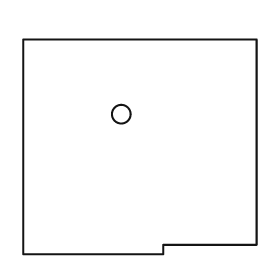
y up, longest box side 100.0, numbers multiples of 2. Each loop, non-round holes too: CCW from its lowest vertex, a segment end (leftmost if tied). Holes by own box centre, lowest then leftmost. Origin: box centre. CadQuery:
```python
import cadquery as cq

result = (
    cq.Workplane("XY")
    .moveTo(-50.0, -46.0)
    .lineTo(10.0, -46.0)
    .lineTo(10.0, -42.0)
    .lineTo(50.0, -42.0)
    .lineTo(50.0, 46.0)
    .lineTo(-50.0, 46.0)
    .close()
    .moveTo(-8.0, 14.0)
    .circle(4.0)
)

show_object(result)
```